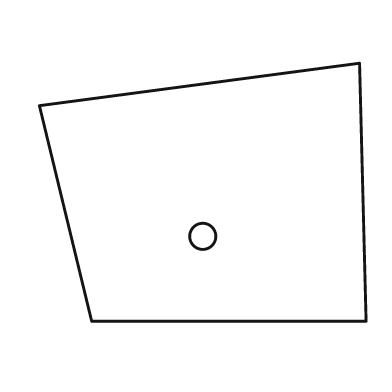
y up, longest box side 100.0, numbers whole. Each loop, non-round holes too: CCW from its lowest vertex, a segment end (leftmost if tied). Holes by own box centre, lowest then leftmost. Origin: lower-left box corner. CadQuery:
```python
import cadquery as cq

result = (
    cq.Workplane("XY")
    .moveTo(16.0, 0.0)
    .lineTo(100.0, 0.0)
    .lineTo(98.0, 79.0)
    .lineTo(0.0, 66.0)
    .close()
    .moveTo(50.0, 26.0)
    .circle(4.0)
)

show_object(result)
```